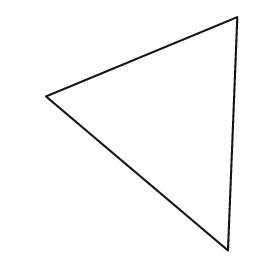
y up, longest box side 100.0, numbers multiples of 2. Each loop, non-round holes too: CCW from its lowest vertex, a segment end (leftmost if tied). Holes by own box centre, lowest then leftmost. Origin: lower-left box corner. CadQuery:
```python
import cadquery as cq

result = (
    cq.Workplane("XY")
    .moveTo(78.0, 0.0)
    .lineTo(82.0, 100.0)
    .lineTo(0.0, 66.0)
    .close()
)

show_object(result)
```